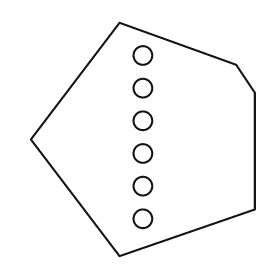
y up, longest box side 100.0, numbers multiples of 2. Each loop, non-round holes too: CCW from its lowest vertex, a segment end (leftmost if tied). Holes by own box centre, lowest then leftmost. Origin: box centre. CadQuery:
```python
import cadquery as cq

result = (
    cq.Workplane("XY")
    .moveTo(-10.0, -50.0)
    .lineTo(48.0, -30.0)
    .lineTo(48.0, 20.0)
    .lineTo(40.0, 32.0)
    .lineTo(-10.0, 50.0)
    .lineTo(-48.0, 0.0)
    .close()
    .moveTo(0.0, -34.0)
    .circle(4.0)
    .moveTo(0.0, -20.0)
    .circle(4.0)
    .moveTo(0.0, -6.0)
    .circle(4.0)
    .moveTo(0.0, 8.0)
    .circle(4.0)
    .moveTo(0.0, 22.0)
    .circle(4.0)
    .moveTo(0.0, 36.0)
    .circle(4.0)
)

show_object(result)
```